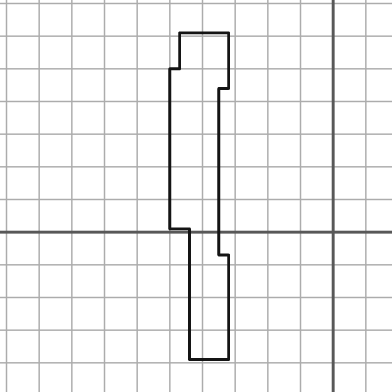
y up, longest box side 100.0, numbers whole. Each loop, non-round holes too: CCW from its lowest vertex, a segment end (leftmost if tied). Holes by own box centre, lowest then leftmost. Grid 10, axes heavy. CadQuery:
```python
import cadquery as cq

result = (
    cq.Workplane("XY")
    .moveTo(-44.0, -39.0)
    .lineTo(-32.0, -39.0)
    .lineTo(-32.0, -7.0)
    .lineTo(-35.0, -7.0)
    .lineTo(-35.0, 44.0)
    .lineTo(-32.0, 44.0)
    .lineTo(-32.0, 61.0)
    .lineTo(-47.0, 61.0)
    .lineTo(-47.0, 50.0)
    .lineTo(-50.0, 50.0)
    .lineTo(-50.0, 1.0)
    .lineTo(-44.0, 1.0)
    .close()
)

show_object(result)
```